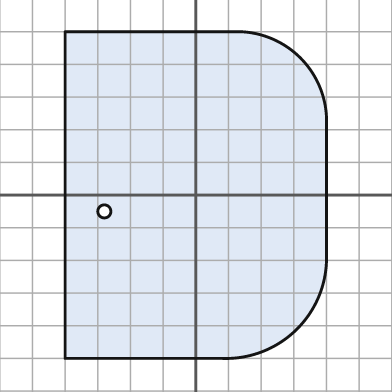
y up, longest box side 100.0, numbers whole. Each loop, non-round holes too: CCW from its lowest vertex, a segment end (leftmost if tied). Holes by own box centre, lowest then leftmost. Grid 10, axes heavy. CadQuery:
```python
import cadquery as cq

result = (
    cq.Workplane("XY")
    .moveTo(-40.0, -50.0)
    .lineTo(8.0, -50.0)
    .threePointArc((31.0, -41.0), (40.0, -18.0))
    .lineTo(40.0, 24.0)
    .threePointArc((32.0, 42.0), (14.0, 50.0))
    .lineTo(-40.0, 50.0)
    .close()
    .moveTo(-28.0, -5.0)
    .circle(2.0)
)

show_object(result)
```